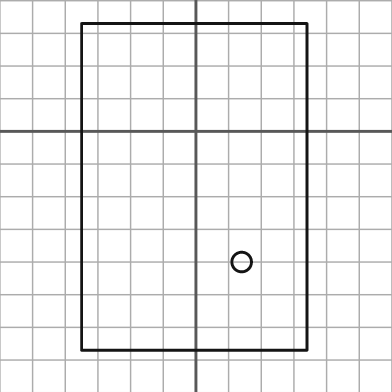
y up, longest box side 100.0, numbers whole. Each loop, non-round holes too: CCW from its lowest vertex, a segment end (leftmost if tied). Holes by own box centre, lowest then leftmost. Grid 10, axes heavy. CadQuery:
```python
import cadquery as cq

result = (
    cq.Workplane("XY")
    .moveTo(-35.0, -67.0)
    .lineTo(34.0, -67.0)
    .lineTo(34.0, 33.0)
    .lineTo(-35.0, 33.0)
    .close()
    .moveTo(14.0, -40.0)
    .circle(3.0)
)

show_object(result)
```